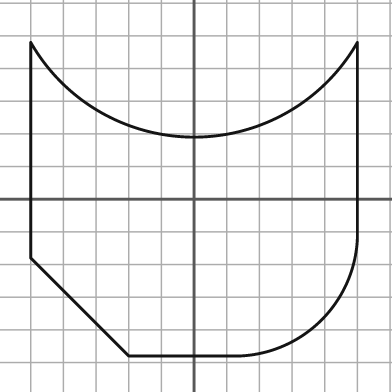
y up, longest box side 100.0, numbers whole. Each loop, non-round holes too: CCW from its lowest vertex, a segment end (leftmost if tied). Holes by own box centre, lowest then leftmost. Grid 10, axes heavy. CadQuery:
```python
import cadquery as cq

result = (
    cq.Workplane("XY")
    .moveTo(-20.0, -48.0)
    .lineTo(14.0, -48.0)
    .threePointArc((39.0, -37.0), (50.0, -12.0))
    .lineTo(50.0, 48.0)
    .threePointArc((0.0, 19.0), (-50.0, 48.0))
    .lineTo(-50.0, -18.0)
    .close()
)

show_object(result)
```